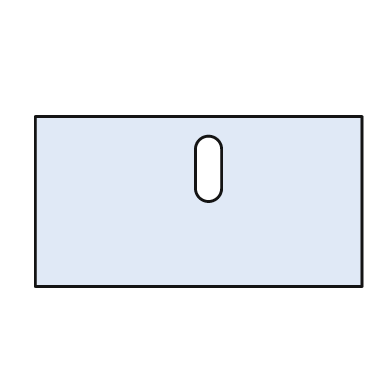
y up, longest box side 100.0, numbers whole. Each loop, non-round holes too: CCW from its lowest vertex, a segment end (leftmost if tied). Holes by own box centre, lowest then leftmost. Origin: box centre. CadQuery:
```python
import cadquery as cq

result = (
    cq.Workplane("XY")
    .moveTo(-50.0, -26.0)
    .lineTo(50.0, -26.0)
    .lineTo(50.0, 26.0)
    .lineTo(-50.0, 26.0)
    .close()
    .moveTo(-1.0, 4.0)
    .threePointArc((3.0, 0.0), (7.0, 4.0))
    .lineTo(7.0, 16.0)
    .threePointArc((3.0, 20.0), (-1.0, 16.0))
    .close()
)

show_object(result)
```